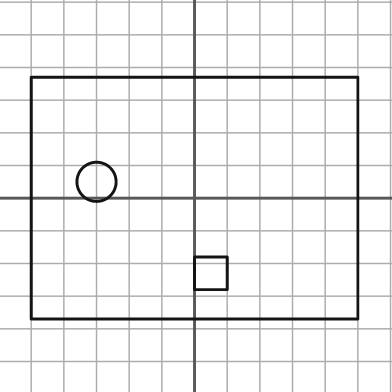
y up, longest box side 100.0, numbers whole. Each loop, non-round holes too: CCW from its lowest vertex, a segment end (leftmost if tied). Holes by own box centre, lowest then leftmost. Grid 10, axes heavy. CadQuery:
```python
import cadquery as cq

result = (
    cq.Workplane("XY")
    .moveTo(-50.0, -37.0)
    .lineTo(50.0, -37.0)
    .lineTo(50.0, 37.0)
    .lineTo(-50.0, 37.0)
    .close()
    .moveTo(0.0, -28.0)
    .lineTo(10.0, -28.0)
    .lineTo(10.0, -18.0)
    .lineTo(0.0, -18.0)
    .close()
    .moveTo(-30.0, 5.0)
    .circle(6.0)
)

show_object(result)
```